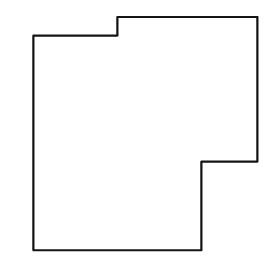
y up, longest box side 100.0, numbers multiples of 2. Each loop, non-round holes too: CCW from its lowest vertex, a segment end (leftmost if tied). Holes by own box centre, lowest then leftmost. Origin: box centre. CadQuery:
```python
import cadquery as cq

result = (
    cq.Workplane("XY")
    .moveTo(-48.0, -50.0)
    .lineTo(24.0, -50.0)
    .lineTo(24.0, -12.0)
    .lineTo(48.0, -12.0)
    .lineTo(48.0, 50.0)
    .lineTo(-12.0, 50.0)
    .lineTo(-12.0, 42.0)
    .lineTo(-48.0, 42.0)
    .close()
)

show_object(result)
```